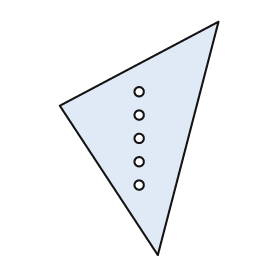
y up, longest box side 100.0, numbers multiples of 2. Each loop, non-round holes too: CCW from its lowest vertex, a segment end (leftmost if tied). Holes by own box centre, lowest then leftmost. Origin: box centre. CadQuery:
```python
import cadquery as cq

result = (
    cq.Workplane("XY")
    .moveTo(8.0, -50.0)
    .lineTo(34.0, 50.0)
    .lineTo(-34.0, 14.0)
    .close()
    .moveTo(0.0, -20.0)
    .circle(2.0)
    .moveTo(0.0, -10.0)
    .circle(2.0)
    .moveTo(0.0, 0.0)
    .circle(2.0)
    .moveTo(0.0, 10.0)
    .circle(2.0)
    .moveTo(0.0, 20.0)
    .circle(2.0)
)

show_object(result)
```